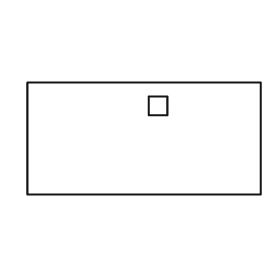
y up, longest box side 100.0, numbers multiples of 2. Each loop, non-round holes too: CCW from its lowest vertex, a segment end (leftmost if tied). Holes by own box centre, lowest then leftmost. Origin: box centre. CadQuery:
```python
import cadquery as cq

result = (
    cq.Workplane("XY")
    .moveTo(-50.0, -24.0)
    .lineTo(50.0, -24.0)
    .lineTo(50.0, 24.0)
    .lineTo(-50.0, 24.0)
    .close()
    .moveTo(2.0, 10.0)
    .lineTo(10.0, 10.0)
    .lineTo(10.0, 18.0)
    .lineTo(2.0, 18.0)
    .close()
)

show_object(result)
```